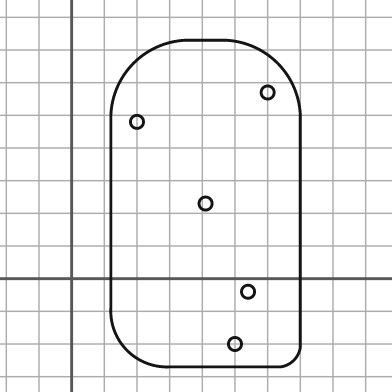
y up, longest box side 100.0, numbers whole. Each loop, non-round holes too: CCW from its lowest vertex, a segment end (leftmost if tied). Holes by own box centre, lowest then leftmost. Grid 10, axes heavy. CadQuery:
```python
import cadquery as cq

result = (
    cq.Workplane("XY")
    .moveTo(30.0, -27.0)
    .lineTo(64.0, -27.0)
    .threePointArc((68.0, -25.0), (70.0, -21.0))
    .lineTo(70.0, 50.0)
    .threePointArc((63.0, 66.0), (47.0, 73.0))
    .lineTo(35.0, 73.0)
    .threePointArc((19.0, 66.0), (12.0, 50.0))
    .lineTo(12.0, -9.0)
    .threePointArc((17.0, -22.0), (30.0, -27.0))
    .close()
    .moveTo(50.0, -20.0)
    .circle(2.0)
    .moveTo(54.0, -4.0)
    .circle(2.0)
    .moveTo(41.0, 23.0)
    .circle(2.0)
    .moveTo(20.0, 48.0)
    .circle(2.0)
    .moveTo(60.0, 57.0)
    .circle(2.0)
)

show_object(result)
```